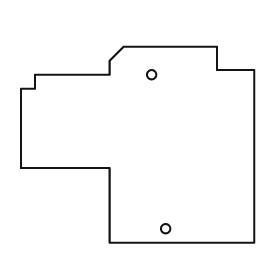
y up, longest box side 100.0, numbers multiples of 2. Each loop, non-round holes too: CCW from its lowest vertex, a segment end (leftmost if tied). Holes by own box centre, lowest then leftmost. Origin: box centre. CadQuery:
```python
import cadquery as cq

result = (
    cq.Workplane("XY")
    .moveTo(-12.0, -42.0)
    .lineTo(50.0, -42.0)
    .lineTo(50.0, 32.0)
    .lineTo(34.0, 32.0)
    .lineTo(34.0, 42.0)
    .lineTo(-6.0, 42.0)
    .lineTo(-12.0, 36.0)
    .lineTo(-12.0, 30.0)
    .lineTo(-44.0, 30.0)
    .lineTo(-44.0, 24.0)
    .lineTo(-50.0, 24.0)
    .lineTo(-50.0, -10.0)
    .lineTo(-12.0, -10.0)
    .close()
    .moveTo(12.0, -36.0)
    .circle(2.0)
    .moveTo(6.0, 30.0)
    .circle(2.0)
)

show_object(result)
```